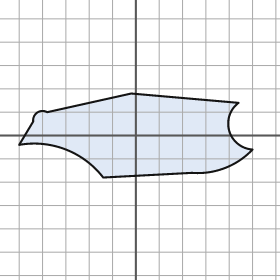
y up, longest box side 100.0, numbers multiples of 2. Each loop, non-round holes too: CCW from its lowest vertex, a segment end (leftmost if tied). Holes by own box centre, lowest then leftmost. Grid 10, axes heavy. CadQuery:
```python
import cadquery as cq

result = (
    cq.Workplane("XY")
    .moveTo(-14.0, -18.0)
    .lineTo(24.0, -16.0)
    .threePointArc((38.0, -14.0), (50.0, -6.0))
    .threePointArc((40.0, 2.0), (44.0, 14.0))
    .lineTo(-2.0, 18.0)
    .lineTo(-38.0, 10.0)
    .threePointArc((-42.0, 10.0), (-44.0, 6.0))
    .lineTo(-50.0, -4.0)
    .threePointArc((-30.0, -6.0), (-14.0, -18.0))
    .close()
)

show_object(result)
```